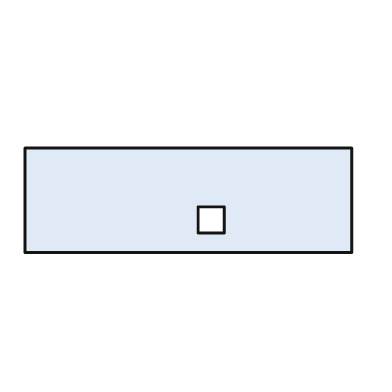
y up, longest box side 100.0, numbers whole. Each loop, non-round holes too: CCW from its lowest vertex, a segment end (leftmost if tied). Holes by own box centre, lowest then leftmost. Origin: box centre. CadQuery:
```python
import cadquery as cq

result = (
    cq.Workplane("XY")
    .moveTo(-50.0, -16.0)
    .lineTo(50.0, -16.0)
    .lineTo(50.0, 16.0)
    .lineTo(-50.0, 16.0)
    .close()
    .moveTo(3.0, -10.0)
    .lineTo(11.0, -10.0)
    .lineTo(11.0, -2.0)
    .lineTo(3.0, -2.0)
    .close()
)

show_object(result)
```